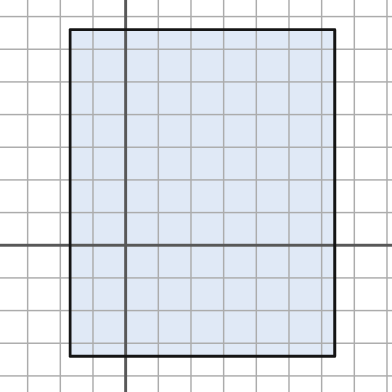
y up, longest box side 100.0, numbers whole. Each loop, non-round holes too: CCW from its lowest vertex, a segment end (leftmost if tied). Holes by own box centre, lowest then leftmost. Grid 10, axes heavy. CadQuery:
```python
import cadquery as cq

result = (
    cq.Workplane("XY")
    .moveTo(-17.0, -34.0)
    .lineTo(64.0, -34.0)
    .lineTo(64.0, 66.0)
    .lineTo(-17.0, 66.0)
    .close()
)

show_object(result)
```